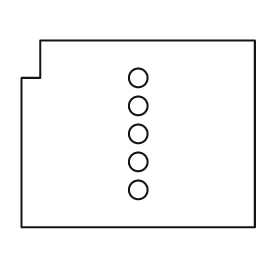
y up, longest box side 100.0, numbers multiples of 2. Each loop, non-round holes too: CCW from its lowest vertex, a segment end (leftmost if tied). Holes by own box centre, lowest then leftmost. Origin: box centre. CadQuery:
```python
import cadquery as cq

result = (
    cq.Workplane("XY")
    .moveTo(-50.0, -40.0)
    .lineTo(50.0, -40.0)
    .lineTo(50.0, 40.0)
    .lineTo(-42.0, 40.0)
    .lineTo(-42.0, 24.0)
    .lineTo(-50.0, 24.0)
    .close()
    .moveTo(0.0, -24.0)
    .circle(4.0)
    .moveTo(0.0, -12.0)
    .circle(4.0)
    .moveTo(0.0, 0.0)
    .circle(4.0)
    .moveTo(0.0, 12.0)
    .circle(4.0)
    .moveTo(0.0, 24.0)
    .circle(4.0)
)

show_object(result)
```